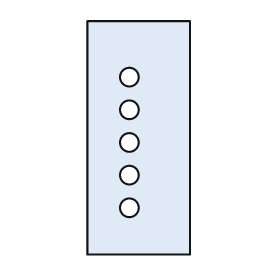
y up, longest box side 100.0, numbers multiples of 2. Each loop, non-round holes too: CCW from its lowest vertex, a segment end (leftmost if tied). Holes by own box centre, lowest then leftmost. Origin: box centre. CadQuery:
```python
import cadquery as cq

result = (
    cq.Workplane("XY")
    .moveTo(-22.0, -50.0)
    .lineTo(22.0, -50.0)
    .lineTo(22.0, 50.0)
    .lineTo(-22.0, 50.0)
    .close()
    .moveTo(-4.0, -30.0)
    .circle(4.0)
    .moveTo(-4.0, -16.0)
    .circle(4.0)
    .moveTo(-4.0, -2.0)
    .circle(4.0)
    .moveTo(-4.0, 12.0)
    .circle(4.0)
    .moveTo(-4.0, 26.0)
    .circle(4.0)
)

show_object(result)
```